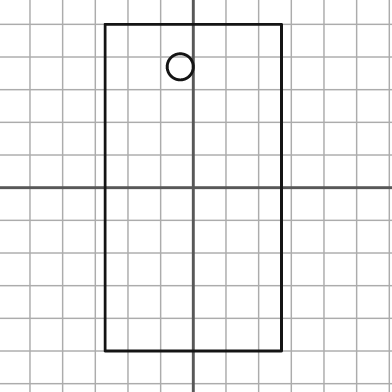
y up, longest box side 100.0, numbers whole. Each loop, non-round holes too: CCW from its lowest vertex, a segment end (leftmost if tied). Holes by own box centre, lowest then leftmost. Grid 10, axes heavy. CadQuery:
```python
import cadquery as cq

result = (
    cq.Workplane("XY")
    .moveTo(-27.0, -50.0)
    .lineTo(27.0, -50.0)
    .lineTo(27.0, 50.0)
    .lineTo(-27.0, 50.0)
    .close()
    .moveTo(-4.0, 37.0)
    .circle(4.0)
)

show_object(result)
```